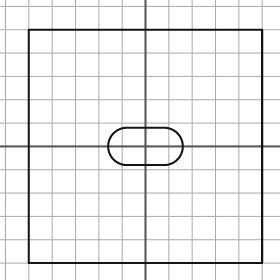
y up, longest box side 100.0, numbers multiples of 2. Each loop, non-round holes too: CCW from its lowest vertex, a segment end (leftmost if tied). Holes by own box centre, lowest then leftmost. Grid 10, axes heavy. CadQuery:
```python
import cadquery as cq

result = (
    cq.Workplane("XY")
    .moveTo(-50.0, -50.0)
    .lineTo(50.0, -50.0)
    .lineTo(50.0, 50.0)
    .lineTo(-50.0, 50.0)
    .close()
    .moveTo(-8.0, -8.0)
    .lineTo(8.0, -8.0)
    .threePointArc((16.0, 0.0), (8.0, 8.0))
    .lineTo(-8.0, 8.0)
    .threePointArc((-16.0, 0.0), (-8.0, -8.0))
    .close()
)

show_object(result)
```